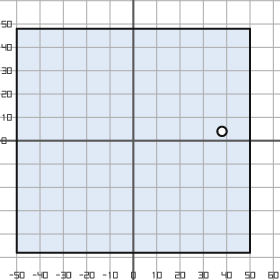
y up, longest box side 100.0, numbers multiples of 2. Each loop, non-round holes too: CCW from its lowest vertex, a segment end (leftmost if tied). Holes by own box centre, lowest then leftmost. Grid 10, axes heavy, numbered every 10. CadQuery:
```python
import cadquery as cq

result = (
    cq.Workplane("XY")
    .moveTo(-50.0, -48.0)
    .lineTo(50.0, -48.0)
    .lineTo(50.0, 48.0)
    .lineTo(-50.0, 48.0)
    .close()
    .moveTo(38.0, 4.0)
    .circle(2.0)
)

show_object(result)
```